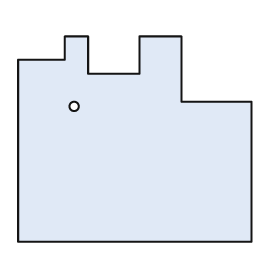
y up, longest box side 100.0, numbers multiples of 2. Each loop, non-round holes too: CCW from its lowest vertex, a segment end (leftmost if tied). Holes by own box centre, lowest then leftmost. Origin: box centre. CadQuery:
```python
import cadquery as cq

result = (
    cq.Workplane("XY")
    .moveTo(-50.0, -44.0)
    .lineTo(50.0, -44.0)
    .lineTo(50.0, 16.0)
    .lineTo(20.0, 16.0)
    .lineTo(20.0, 44.0)
    .lineTo(2.0, 44.0)
    .lineTo(2.0, 28.0)
    .lineTo(-20.0, 28.0)
    .lineTo(-20.0, 44.0)
    .lineTo(-30.0, 44.0)
    .lineTo(-30.0, 34.0)
    .lineTo(-50.0, 34.0)
    .close()
    .moveTo(-26.0, 14.0)
    .circle(2.0)
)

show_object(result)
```